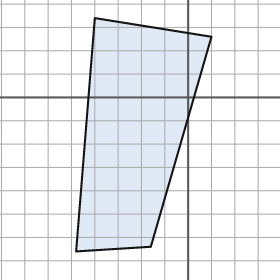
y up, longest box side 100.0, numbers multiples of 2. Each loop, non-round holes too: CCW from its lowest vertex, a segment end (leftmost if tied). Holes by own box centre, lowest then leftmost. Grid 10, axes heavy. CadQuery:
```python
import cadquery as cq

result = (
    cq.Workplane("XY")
    .moveTo(-48.0, -66.0)
    .lineTo(-16.0, -64.0)
    .lineTo(10.0, 26.0)
    .lineTo(-40.0, 34.0)
    .close()
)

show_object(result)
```